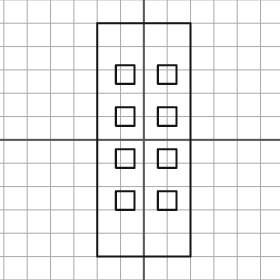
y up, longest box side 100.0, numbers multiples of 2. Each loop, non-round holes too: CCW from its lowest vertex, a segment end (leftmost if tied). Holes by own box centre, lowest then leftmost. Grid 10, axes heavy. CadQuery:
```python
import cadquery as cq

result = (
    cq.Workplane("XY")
    .moveTo(-20.0, -50.0)
    .lineTo(20.0, -50.0)
    .lineTo(20.0, 50.0)
    .lineTo(-20.0, 50.0)
    .close()
    .moveTo(-12.0, -30.0)
    .lineTo(-4.0, -30.0)
    .lineTo(-4.0, -22.0)
    .lineTo(-12.0, -22.0)
    .close()
    .moveTo(6.0, -30.0)
    .lineTo(14.0, -30.0)
    .lineTo(14.0, -22.0)
    .lineTo(6.0, -22.0)
    .close()
    .moveTo(-12.0, -12.0)
    .lineTo(-4.0, -12.0)
    .lineTo(-4.0, -4.0)
    .lineTo(-12.0, -4.0)
    .close()
    .moveTo(6.0, -12.0)
    .lineTo(14.0, -12.0)
    .lineTo(14.0, -4.0)
    .lineTo(6.0, -4.0)
    .close()
    .moveTo(-12.0, 6.0)
    .lineTo(-4.0, 6.0)
    .lineTo(-4.0, 14.0)
    .lineTo(-12.0, 14.0)
    .close()
    .moveTo(6.0, 6.0)
    .lineTo(14.0, 6.0)
    .lineTo(14.0, 14.0)
    .lineTo(6.0, 14.0)
    .close()
    .moveTo(-12.0, 24.0)
    .lineTo(-4.0, 24.0)
    .lineTo(-4.0, 32.0)
    .lineTo(-12.0, 32.0)
    .close()
    .moveTo(6.0, 24.0)
    .lineTo(14.0, 24.0)
    .lineTo(14.0, 32.0)
    .lineTo(6.0, 32.0)
    .close()
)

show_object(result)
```